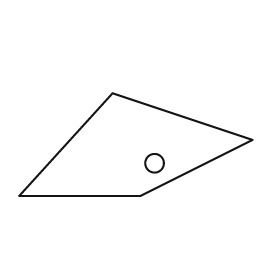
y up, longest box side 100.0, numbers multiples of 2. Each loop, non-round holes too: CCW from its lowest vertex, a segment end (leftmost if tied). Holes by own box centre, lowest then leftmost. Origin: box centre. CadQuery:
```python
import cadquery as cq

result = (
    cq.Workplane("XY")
    .moveTo(-50.0, -22.0)
    .lineTo(2.0, -22.0)
    .lineTo(50.0, 2.0)
    .lineTo(-10.0, 22.0)
    .close()
    .moveTo(8.0, -8.0)
    .circle(4.0)
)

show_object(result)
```